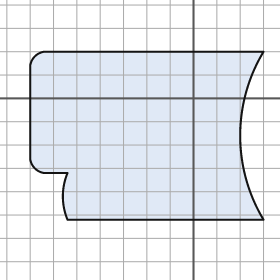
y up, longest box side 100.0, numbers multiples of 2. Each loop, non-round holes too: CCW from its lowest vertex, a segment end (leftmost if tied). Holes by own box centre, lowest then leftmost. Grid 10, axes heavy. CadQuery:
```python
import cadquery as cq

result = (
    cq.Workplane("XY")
    .moveTo(-54.0, -52.0)
    .lineTo(30.0, -52.0)
    .threePointArc((20.0, -16.0), (30.0, 20.0))
    .lineTo(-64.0, 20.0)
    .threePointArc((-68.0, 18.0), (-70.0, 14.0))
    .lineTo(-70.0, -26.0)
    .threePointArc((-68.0, -30.0), (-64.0, -32.0))
    .lineTo(-54.0, -32.0)
    .threePointArc((-56.0, -42.0), (-54.0, -52.0))
    .close()
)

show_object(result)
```